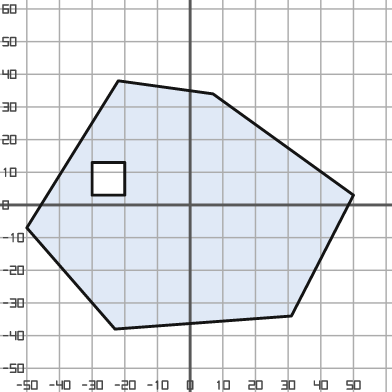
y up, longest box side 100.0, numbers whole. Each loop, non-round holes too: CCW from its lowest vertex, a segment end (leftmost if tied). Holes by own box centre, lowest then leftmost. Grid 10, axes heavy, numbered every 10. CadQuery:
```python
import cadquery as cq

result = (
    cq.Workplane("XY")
    .moveTo(-23.0, -38.0)
    .lineTo(31.0, -34.0)
    .lineTo(50.0, 3.0)
    .lineTo(7.0, 34.0)
    .lineTo(-22.0, 38.0)
    .lineTo(-50.0, -7.0)
    .close()
    .moveTo(-30.0, 3.0)
    .lineTo(-20.0, 3.0)
    .lineTo(-20.0, 13.0)
    .lineTo(-30.0, 13.0)
    .close()
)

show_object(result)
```